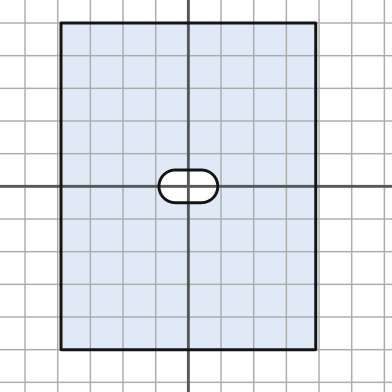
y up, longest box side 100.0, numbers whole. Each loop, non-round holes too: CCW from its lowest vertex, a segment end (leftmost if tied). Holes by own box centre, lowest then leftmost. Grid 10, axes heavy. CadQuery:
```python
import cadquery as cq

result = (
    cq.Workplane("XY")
    .moveTo(-39.0, -50.0)
    .lineTo(39.0, -50.0)
    .lineTo(39.0, 50.0)
    .lineTo(-39.0, 50.0)
    .close()
    .moveTo(-4.0, -5.0)
    .lineTo(4.0, -5.0)
    .threePointArc((9.0, 0.0), (4.0, 5.0))
    .lineTo(-4.0, 5.0)
    .threePointArc((-9.0, 0.0), (-4.0, -5.0))
    .close()
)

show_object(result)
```